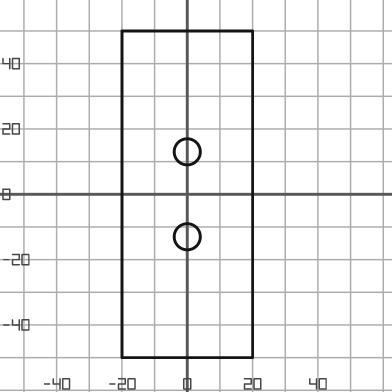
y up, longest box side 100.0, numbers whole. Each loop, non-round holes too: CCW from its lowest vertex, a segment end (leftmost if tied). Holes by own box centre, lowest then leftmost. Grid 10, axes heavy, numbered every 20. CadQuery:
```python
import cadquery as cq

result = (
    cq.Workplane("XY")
    .moveTo(-20.0, -50.0)
    .lineTo(20.0, -50.0)
    .lineTo(20.0, 50.0)
    .lineTo(-20.0, 50.0)
    .close()
    .moveTo(0.0, -13.0)
    .circle(4.0)
    .moveTo(0.0, 13.0)
    .circle(4.0)
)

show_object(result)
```